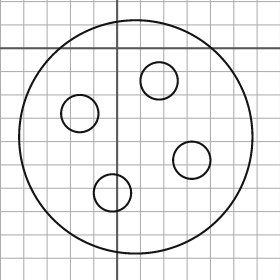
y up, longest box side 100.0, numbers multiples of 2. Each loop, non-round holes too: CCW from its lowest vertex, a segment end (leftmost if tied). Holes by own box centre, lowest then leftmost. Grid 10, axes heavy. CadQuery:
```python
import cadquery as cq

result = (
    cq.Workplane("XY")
    .moveTo(8.0, -38.0)
    .circle(50.0)
    .moveTo(-2.0, -62.0)
    .circle(8.0)
    .moveTo(32.0, -48.0)
    .circle(8.0)
    .moveTo(-16.0, -28.0)
    .circle(8.0)
    .moveTo(18.0, -14.0)
    .circle(8.0)
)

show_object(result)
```